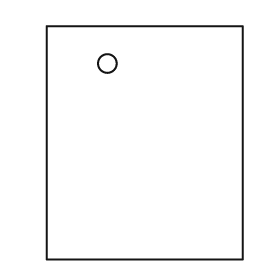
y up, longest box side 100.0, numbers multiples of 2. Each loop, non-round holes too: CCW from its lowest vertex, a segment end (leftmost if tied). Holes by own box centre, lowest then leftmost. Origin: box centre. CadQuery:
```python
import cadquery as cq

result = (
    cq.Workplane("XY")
    .moveTo(-42.0, -50.0)
    .lineTo(42.0, -50.0)
    .lineTo(42.0, 50.0)
    .lineTo(-42.0, 50.0)
    .close()
    .moveTo(-16.0, 34.0)
    .circle(4.0)
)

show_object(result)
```